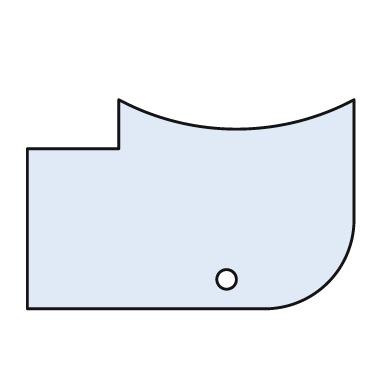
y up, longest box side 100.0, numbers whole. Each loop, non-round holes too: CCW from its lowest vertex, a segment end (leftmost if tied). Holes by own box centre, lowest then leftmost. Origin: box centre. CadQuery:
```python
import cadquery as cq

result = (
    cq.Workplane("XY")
    .moveTo(-50.0, -32.0)
    .lineTo(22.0, -32.0)
    .threePointArc((42.0, -24.0), (50.0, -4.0))
    .lineTo(50.0, 32.0)
    .threePointArc((14.0, 23.0), (-22.0, 32.0))
    .lineTo(-22.0, 17.0)
    .lineTo(-50.0, 17.0)
    .close()
    .moveTo(11.0, -23.0)
    .circle(3.0)
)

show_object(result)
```